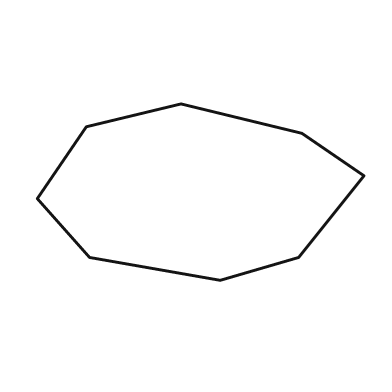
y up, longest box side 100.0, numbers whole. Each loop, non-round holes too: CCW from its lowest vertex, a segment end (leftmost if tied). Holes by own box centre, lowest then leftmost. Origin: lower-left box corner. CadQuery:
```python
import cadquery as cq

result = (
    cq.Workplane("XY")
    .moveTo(56.0, 0.0)
    .lineTo(80.0, 7.0)
    .lineTo(100.0, 32.0)
    .lineTo(81.0, 45.0)
    .lineTo(44.0, 54.0)
    .lineTo(15.0, 47.0)
    .lineTo(0.0, 25.0)
    .lineTo(16.0, 7.0)
    .close()
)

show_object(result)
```